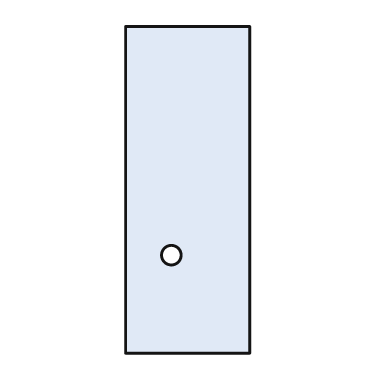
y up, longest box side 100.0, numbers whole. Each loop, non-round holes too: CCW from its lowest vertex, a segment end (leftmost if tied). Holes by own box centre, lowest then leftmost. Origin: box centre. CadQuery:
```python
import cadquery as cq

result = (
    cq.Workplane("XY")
    .moveTo(-19.0, -50.0)
    .lineTo(19.0, -50.0)
    .lineTo(19.0, 50.0)
    .lineTo(-19.0, 50.0)
    .close()
    .moveTo(-5.0, -20.0)
    .circle(3.0)
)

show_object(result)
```